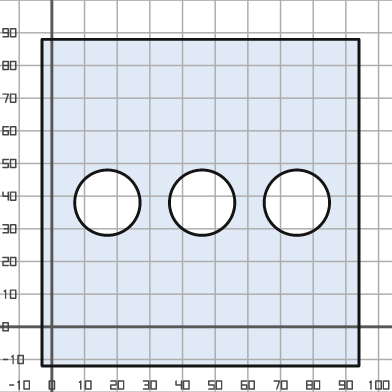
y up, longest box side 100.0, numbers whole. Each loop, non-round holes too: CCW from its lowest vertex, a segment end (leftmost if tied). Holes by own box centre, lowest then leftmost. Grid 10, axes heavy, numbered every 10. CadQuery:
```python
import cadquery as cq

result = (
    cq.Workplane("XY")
    .moveTo(-3.0, -12.0)
    .lineTo(94.0, -12.0)
    .lineTo(94.0, 88.0)
    .lineTo(-3.0, 88.0)
    .close()
    .moveTo(17.0, 38.0)
    .circle(10.0)
    .moveTo(46.0, 38.0)
    .circle(10.0)
    .moveTo(75.0, 38.0)
    .circle(10.0)
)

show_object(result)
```